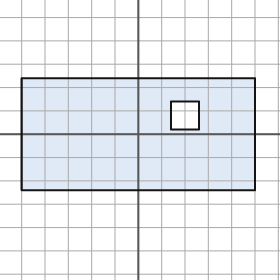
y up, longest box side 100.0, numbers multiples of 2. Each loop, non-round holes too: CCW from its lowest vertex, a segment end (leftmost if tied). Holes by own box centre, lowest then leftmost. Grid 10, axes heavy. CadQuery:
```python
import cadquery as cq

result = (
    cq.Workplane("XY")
    .moveTo(-50.0, -24.0)
    .lineTo(50.0, -24.0)
    .lineTo(50.0, 24.0)
    .lineTo(-50.0, 24.0)
    .close()
    .moveTo(14.0, 2.0)
    .lineTo(26.0, 2.0)
    .lineTo(26.0, 14.0)
    .lineTo(14.0, 14.0)
    .close()
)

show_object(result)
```